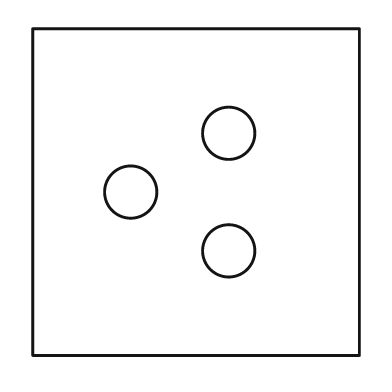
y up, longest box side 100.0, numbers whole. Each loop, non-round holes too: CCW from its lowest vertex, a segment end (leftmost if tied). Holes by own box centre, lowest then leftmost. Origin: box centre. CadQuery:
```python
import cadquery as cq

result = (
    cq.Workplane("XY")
    .moveTo(-50.0, -50.0)
    .lineTo(50.0, -50.0)
    .lineTo(50.0, 50.0)
    .lineTo(-50.0, 50.0)
    .close()
    .moveTo(10.0, -18.0)
    .circle(8.0)
    .moveTo(-20.0, 0.0)
    .circle(8.0)
    .moveTo(10.0, 18.0)
    .circle(8.0)
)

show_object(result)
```